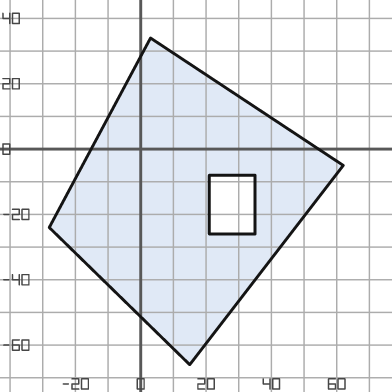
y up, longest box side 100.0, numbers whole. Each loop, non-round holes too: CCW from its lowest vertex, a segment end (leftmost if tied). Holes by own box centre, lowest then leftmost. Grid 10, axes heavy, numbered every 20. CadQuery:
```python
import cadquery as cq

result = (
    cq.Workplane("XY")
    .moveTo(15.0, -66.0)
    .lineTo(62.0, -5.0)
    .lineTo(3.0, 34.0)
    .lineTo(-28.0, -24.0)
    .close()
    .moveTo(21.0, -26.0)
    .lineTo(35.0, -26.0)
    .lineTo(35.0, -8.0)
    .lineTo(21.0, -8.0)
    .close()
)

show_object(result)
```